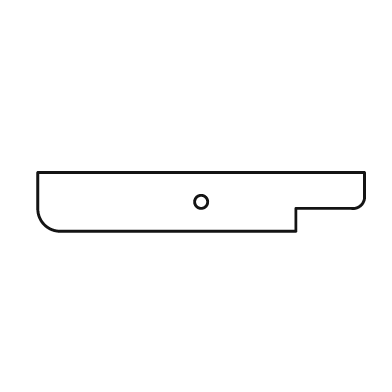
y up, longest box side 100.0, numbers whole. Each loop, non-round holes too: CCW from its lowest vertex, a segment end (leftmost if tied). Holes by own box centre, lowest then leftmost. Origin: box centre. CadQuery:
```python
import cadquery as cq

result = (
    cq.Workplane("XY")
    .moveTo(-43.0, -9.0)
    .lineTo(29.0, -9.0)
    .lineTo(29.0, -2.0)
    .lineTo(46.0, -2.0)
    .threePointArc((49.0, -1.0), (50.0, 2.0))
    .lineTo(50.0, 9.0)
    .lineTo(-50.0, 9.0)
    .lineTo(-50.0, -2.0)
    .threePointArc((-48.0, -7.0), (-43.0, -9.0))
    .close()
    .moveTo(0.0, 0.0)
    .circle(2.0)
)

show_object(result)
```